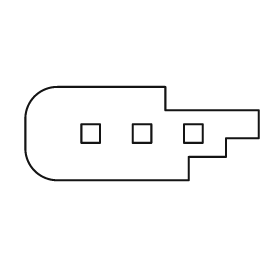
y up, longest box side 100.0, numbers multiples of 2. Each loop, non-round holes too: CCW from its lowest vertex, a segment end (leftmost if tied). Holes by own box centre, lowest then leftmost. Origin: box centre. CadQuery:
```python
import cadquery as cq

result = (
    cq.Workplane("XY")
    .moveTo(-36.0, -20.0)
    .lineTo(20.0, -20.0)
    .lineTo(20.0, -10.0)
    .lineTo(36.0, -10.0)
    .lineTo(36.0, -2.0)
    .lineTo(50.0, -2.0)
    .lineTo(50.0, 10.0)
    .lineTo(10.0, 10.0)
    .lineTo(10.0, 20.0)
    .lineTo(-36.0, 20.0)
    .threePointArc((-46.0, 16.0), (-50.0, 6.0))
    .lineTo(-50.0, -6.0)
    .threePointArc((-46.0, -16.0), (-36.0, -20.0))
    .close()
    .moveTo(-26.0, -4.0)
    .lineTo(-18.0, -4.0)
    .lineTo(-18.0, 4.0)
    .lineTo(-26.0, 4.0)
    .close()
    .moveTo(-4.0, -4.0)
    .lineTo(4.0, -4.0)
    .lineTo(4.0, 4.0)
    .lineTo(-4.0, 4.0)
    .close()
    .moveTo(18.0, -4.0)
    .lineTo(26.0, -4.0)
    .lineTo(26.0, 4.0)
    .lineTo(18.0, 4.0)
    .close()
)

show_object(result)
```